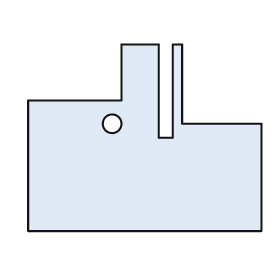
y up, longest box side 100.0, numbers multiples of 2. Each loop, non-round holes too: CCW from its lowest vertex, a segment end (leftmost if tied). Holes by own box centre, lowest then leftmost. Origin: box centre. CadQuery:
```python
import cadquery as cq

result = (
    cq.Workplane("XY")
    .moveTo(-50.0, -40.0)
    .lineTo(50.0, -40.0)
    .lineTo(50.0, 6.0)
    .lineTo(16.0, 6.0)
    .lineTo(16.0, 40.0)
    .lineTo(12.0, 40.0)
    .lineTo(12.0, 0.0)
    .lineTo(6.0, 0.0)
    .lineTo(6.0, 40.0)
    .lineTo(-10.0, 40.0)
    .lineTo(-10.0, 16.0)
    .lineTo(-50.0, 16.0)
    .close()
    .moveTo(-14.0, 6.0)
    .circle(4.0)
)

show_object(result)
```